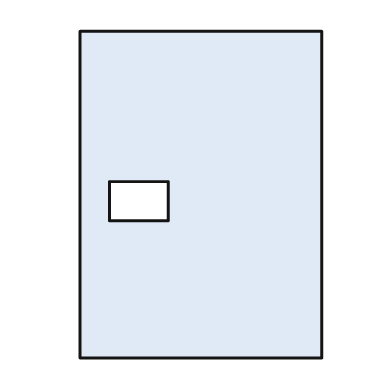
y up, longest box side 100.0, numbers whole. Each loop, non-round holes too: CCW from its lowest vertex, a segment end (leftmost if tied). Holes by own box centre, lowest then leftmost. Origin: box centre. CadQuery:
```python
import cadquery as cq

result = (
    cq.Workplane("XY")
    .moveTo(-37.0, -50.0)
    .lineTo(37.0, -50.0)
    .lineTo(37.0, 50.0)
    .lineTo(-37.0, 50.0)
    .close()
    .moveTo(-28.0, -8.0)
    .lineTo(-10.0, -8.0)
    .lineTo(-10.0, 4.0)
    .lineTo(-28.0, 4.0)
    .close()
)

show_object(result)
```